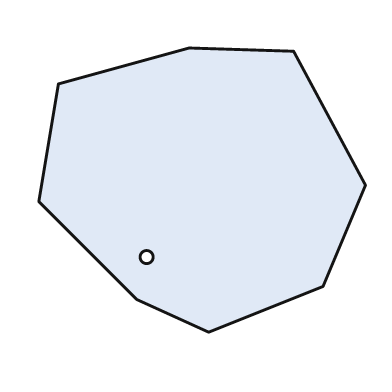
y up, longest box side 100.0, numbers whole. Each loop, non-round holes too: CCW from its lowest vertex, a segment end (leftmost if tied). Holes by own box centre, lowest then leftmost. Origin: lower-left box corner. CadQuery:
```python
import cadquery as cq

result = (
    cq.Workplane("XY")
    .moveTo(52.0, 0.0)
    .lineTo(87.0, 14.0)
    .lineTo(100.0, 45.0)
    .lineTo(78.0, 86.0)
    .lineTo(46.0, 87.0)
    .lineTo(6.0, 76.0)
    .lineTo(0.0, 40.0)
    .lineTo(30.0, 10.0)
    .close()
    .moveTo(33.0, 23.0)
    .circle(2.0)
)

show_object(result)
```